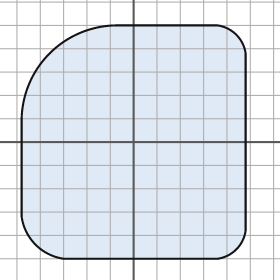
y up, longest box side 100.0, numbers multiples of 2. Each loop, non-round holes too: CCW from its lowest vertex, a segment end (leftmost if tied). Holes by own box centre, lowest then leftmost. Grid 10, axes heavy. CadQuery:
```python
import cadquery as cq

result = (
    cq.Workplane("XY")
    .moveTo(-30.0, -50.0)
    .lineTo(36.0, -50.0)
    .threePointArc((44.0, -46.0), (48.0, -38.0))
    .lineTo(48.0, 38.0)
    .threePointArc((44.0, 46.0), (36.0, 50.0))
    .lineTo(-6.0, 50.0)
    .threePointArc((-36.0, 38.0), (-48.0, 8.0))
    .lineTo(-48.0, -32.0)
    .threePointArc((-42.0, -44.0), (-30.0, -50.0))
    .close()
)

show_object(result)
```